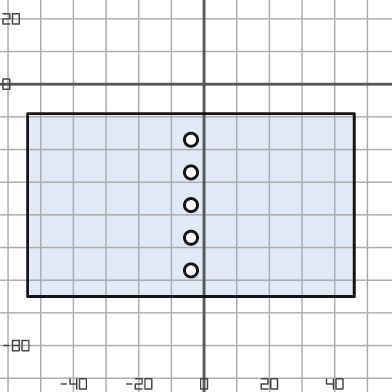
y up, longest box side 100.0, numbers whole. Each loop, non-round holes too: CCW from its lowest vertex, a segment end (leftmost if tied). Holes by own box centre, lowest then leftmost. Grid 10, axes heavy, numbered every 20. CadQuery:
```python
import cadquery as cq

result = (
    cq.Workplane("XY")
    .moveTo(-54.0, -65.0)
    .lineTo(46.0, -65.0)
    .lineTo(46.0, -9.0)
    .lineTo(-54.0, -9.0)
    .close()
    .moveTo(-4.0, -57.0)
    .circle(2.0)
    .moveTo(-4.0, -47.0)
    .circle(2.0)
    .moveTo(-4.0, -37.0)
    .circle(2.0)
    .moveTo(-4.0, -27.0)
    .circle(2.0)
    .moveTo(-4.0, -17.0)
    .circle(2.0)
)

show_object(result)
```